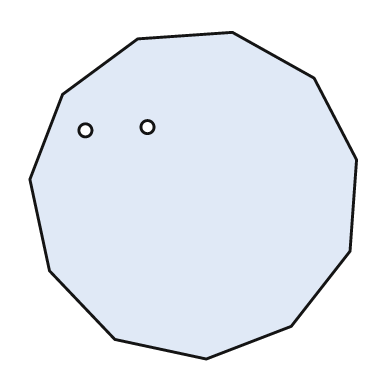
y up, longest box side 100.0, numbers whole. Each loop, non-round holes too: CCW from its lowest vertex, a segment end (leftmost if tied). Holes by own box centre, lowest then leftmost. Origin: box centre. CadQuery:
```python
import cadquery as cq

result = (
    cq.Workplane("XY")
    .moveTo(4.0, -50.0)
    .lineTo(30.0, -40.0)
    .lineTo(48.0, -17.0)
    .lineTo(50.0, 11.0)
    .lineTo(37.0, 36.0)
    .lineTo(12.0, 50.0)
    .lineTo(-17.0, 48.0)
    .lineTo(-40.0, 31.0)
    .lineTo(-50.0, 5.0)
    .lineTo(-44.0, -23.0)
    .lineTo(-24.0, -44.0)
    .close()
    .moveTo(-33.0, 20.0)
    .circle(2.0)
    .moveTo(-14.0, 21.0)
    .circle(2.0)
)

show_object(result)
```